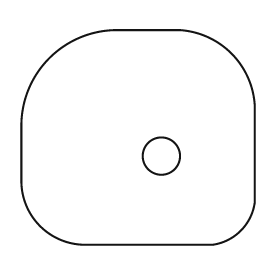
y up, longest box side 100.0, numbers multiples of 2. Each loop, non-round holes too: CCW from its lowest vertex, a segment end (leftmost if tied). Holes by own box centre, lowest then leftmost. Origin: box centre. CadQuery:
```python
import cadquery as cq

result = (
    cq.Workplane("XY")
    .moveTo(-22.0, -46.0)
    .lineTo(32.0, -46.0)
    .threePointArc((44.0, -40.0), (50.0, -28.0))
    .lineTo(50.0, 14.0)
    .threePointArc((40.0, 36.0), (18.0, 46.0))
    .lineTo(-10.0, 46.0)
    .threePointArc((-38.0, 34.0), (-50.0, 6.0))
    .lineTo(-50.0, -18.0)
    .threePointArc((-42.0, -38.0), (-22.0, -46.0))
    .close()
    .moveTo(10.0, -8.0)
    .circle(8.0)
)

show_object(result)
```